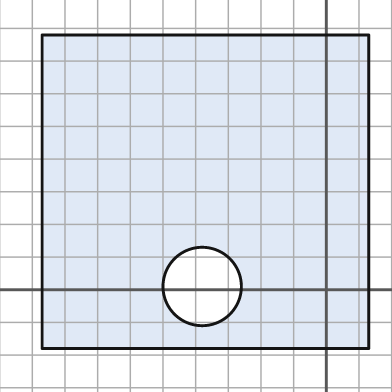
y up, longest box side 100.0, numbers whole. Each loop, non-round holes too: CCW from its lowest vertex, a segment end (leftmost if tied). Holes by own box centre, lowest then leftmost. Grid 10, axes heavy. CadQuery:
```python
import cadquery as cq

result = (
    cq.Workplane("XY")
    .moveTo(-87.0, -18.0)
    .lineTo(13.0, -18.0)
    .lineTo(13.0, 78.0)
    .lineTo(-87.0, 78.0)
    .close()
    .moveTo(-38.0, 1.0)
    .circle(12.0)
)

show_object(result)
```